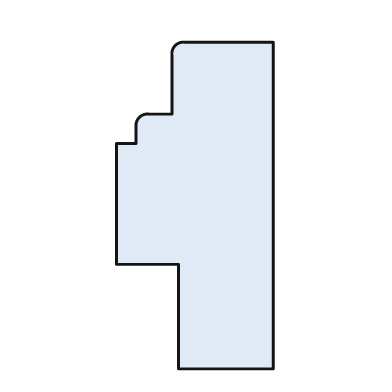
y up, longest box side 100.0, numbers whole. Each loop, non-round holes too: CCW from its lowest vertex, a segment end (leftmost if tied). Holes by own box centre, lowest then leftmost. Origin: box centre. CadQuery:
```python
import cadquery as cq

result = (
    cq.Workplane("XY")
    .moveTo(-5.0, -50.0)
    .lineTo(24.0, -50.0)
    .lineTo(24.0, 50.0)
    .lineTo(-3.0, 50.0)
    .threePointArc((-6.0, 49.0), (-7.0, 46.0))
    .lineTo(-7.0, 28.0)
    .lineTo(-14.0, 28.0)
    .threePointArc((-17.0, 27.0), (-18.0, 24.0))
    .lineTo(-18.0, 19.0)
    .lineTo(-24.0, 19.0)
    .lineTo(-24.0, -18.0)
    .lineTo(-5.0, -18.0)
    .close()
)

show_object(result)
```